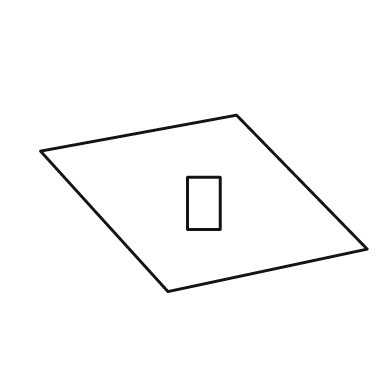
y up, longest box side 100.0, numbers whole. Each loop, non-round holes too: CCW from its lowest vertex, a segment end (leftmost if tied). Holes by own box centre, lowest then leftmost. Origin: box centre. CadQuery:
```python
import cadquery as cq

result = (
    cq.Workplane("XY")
    .moveTo(-11.0, -27.0)
    .lineTo(50.0, -14.0)
    .lineTo(10.0, 27.0)
    .lineTo(-50.0, 16.0)
    .close()
    .moveTo(-5.0, -8.0)
    .lineTo(5.0, -8.0)
    .lineTo(5.0, 8.0)
    .lineTo(-5.0, 8.0)
    .close()
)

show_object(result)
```